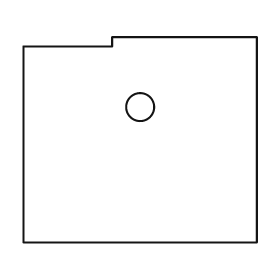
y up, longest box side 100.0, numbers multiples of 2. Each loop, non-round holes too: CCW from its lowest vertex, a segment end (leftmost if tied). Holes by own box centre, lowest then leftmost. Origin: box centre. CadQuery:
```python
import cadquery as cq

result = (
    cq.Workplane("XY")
    .moveTo(-50.0, -44.0)
    .lineTo(50.0, -44.0)
    .lineTo(50.0, 44.0)
    .lineTo(-12.0, 44.0)
    .lineTo(-12.0, 40.0)
    .lineTo(-50.0, 40.0)
    .close()
    .moveTo(0.0, 14.0)
    .circle(6.0)
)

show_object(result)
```